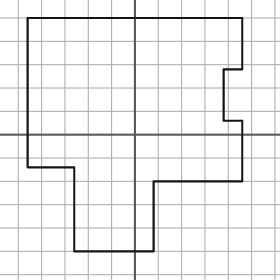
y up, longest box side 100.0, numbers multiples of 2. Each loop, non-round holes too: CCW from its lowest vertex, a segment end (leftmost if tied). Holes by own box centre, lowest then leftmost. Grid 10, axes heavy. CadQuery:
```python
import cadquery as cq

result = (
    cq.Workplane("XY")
    .moveTo(-26.0, -50.0)
    .lineTo(8.0, -50.0)
    .lineTo(8.0, -20.0)
    .lineTo(46.0, -20.0)
    .lineTo(46.0, 6.0)
    .lineTo(38.0, 6.0)
    .lineTo(38.0, 28.0)
    .lineTo(46.0, 28.0)
    .lineTo(46.0, 50.0)
    .lineTo(-46.0, 50.0)
    .lineTo(-46.0, -14.0)
    .lineTo(-26.0, -14.0)
    .close()
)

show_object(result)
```